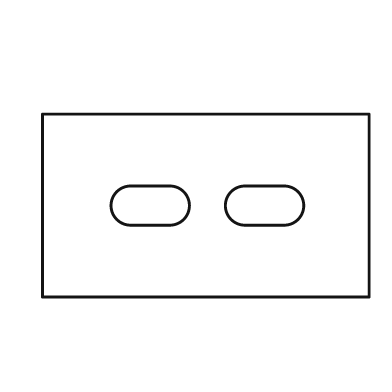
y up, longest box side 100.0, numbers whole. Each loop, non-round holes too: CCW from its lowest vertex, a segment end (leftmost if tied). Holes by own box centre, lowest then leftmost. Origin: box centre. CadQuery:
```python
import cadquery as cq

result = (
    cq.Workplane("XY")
    .moveTo(-50.0, -28.0)
    .lineTo(50.0, -28.0)
    .lineTo(50.0, 28.0)
    .lineTo(-50.0, 28.0)
    .close()
    .moveTo(-23.0, -6.0)
    .lineTo(-11.0, -6.0)
    .threePointArc((-5.0, 0.0), (-11.0, 6.0))
    .lineTo(-23.0, 6.0)
    .threePointArc((-29.0, 0.0), (-23.0, -6.0))
    .close()
    .moveTo(12.0, -6.0)
    .lineTo(24.0, -6.0)
    .threePointArc((30.0, 0.0), (24.0, 6.0))
    .lineTo(12.0, 6.0)
    .threePointArc((6.0, 0.0), (12.0, -6.0))
    .close()
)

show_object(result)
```